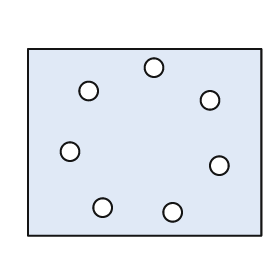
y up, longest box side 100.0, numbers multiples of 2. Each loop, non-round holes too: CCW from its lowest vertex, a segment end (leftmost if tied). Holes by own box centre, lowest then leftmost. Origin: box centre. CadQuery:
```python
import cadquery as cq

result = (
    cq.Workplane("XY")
    .moveTo(-50.0, -40.0)
    .lineTo(50.0, -40.0)
    .lineTo(50.0, 40.0)
    .lineTo(-50.0, 40.0)
    .close()
    .moveTo(12.0, -30.0)
    .circle(4.0)
    .moveTo(-18.0, -28.0)
    .circle(4.0)
    .moveTo(32.0, -10.0)
    .circle(4.0)
    .moveTo(-32.0, -4.0)
    .circle(4.0)
    .moveTo(28.0, 18.0)
    .circle(4.0)
    .moveTo(-24.0, 22.0)
    .circle(4.0)
    .moveTo(4.0, 32.0)
    .circle(4.0)
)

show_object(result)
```